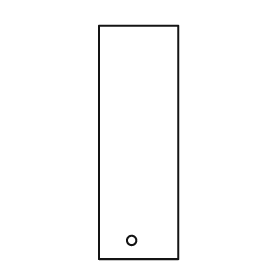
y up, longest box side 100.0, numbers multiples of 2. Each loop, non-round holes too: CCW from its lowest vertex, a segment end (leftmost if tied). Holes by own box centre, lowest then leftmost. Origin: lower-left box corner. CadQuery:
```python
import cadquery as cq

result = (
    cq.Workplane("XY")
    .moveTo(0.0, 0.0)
    .lineTo(34.0, 0.0)
    .lineTo(34.0, 100.0)
    .lineTo(0.0, 100.0)
    .close()
    .moveTo(14.0, 8.0)
    .circle(2.0)
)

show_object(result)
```